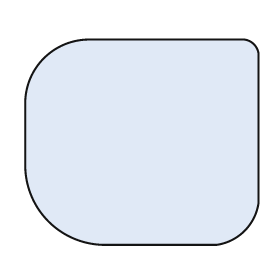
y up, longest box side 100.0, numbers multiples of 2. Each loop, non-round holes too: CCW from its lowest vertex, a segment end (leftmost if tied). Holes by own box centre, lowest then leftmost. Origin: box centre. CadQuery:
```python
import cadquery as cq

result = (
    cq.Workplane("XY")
    .moveTo(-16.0, -44.0)
    .lineTo(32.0, -44.0)
    .threePointArc((44.0, -38.0), (50.0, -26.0))
    .lineTo(50.0, 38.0)
    .threePointArc((48.0, 42.0), (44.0, 44.0))
    .lineTo(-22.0, 44.0)
    .threePointArc((-42.0, 36.0), (-50.0, 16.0))
    .lineTo(-50.0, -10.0)
    .threePointArc((-40.0, -34.0), (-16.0, -44.0))
    .close()
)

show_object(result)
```